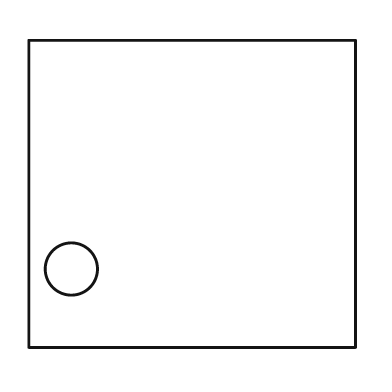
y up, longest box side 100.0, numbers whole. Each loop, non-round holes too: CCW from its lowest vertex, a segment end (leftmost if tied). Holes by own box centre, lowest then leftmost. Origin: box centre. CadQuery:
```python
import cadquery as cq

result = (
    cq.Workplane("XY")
    .moveTo(-50.0, -47.0)
    .lineTo(50.0, -47.0)
    .lineTo(50.0, 47.0)
    .lineTo(-50.0, 47.0)
    .close()
    .moveTo(-37.0, -23.0)
    .circle(8.0)
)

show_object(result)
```